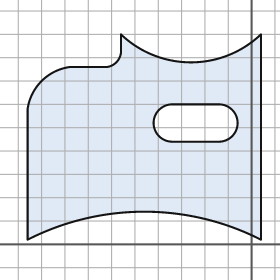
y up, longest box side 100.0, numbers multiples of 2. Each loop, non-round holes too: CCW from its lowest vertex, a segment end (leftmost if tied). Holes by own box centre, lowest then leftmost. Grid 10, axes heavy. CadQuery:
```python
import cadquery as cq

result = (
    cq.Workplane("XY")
    .moveTo(-96.0, 2.0)
    .threePointArc((-46.0, 14.0), (4.0, 2.0))
    .lineTo(4.0, 90.0)
    .threePointArc((-26.0, 78.0), (-56.0, 90.0))
    .lineTo(-56.0, 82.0)
    .threePointArc((-58.0, 78.0), (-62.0, 76.0))
    .lineTo(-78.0, 76.0)
    .threePointArc((-90.0, 70.0), (-96.0, 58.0))
    .close()
    .moveTo(-34.0, 44.0)
    .lineTo(-14.0, 44.0)
    .threePointArc((-6.0, 52.0), (-14.0, 60.0))
    .lineTo(-34.0, 60.0)
    .threePointArc((-42.0, 52.0), (-34.0, 44.0))
    .close()
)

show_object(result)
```